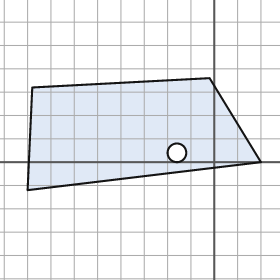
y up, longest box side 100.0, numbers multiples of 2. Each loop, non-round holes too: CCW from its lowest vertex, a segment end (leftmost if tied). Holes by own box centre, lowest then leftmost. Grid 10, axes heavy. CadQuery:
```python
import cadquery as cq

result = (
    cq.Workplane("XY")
    .moveTo(-80.0, -12.0)
    .lineTo(20.0, 0.0)
    .lineTo(-2.0, 36.0)
    .lineTo(-78.0, 32.0)
    .close()
    .moveTo(-16.0, 4.0)
    .circle(4.0)
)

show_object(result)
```